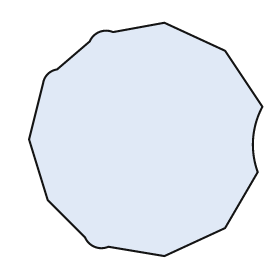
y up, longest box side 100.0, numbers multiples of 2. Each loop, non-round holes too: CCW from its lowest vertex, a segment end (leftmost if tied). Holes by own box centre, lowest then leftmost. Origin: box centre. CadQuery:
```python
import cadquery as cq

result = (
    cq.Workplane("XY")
    .moveTo(8.0, -50.0)
    .lineTo(34.0, -38.0)
    .lineTo(48.0, -14.0)
    .threePointArc((46.0, 0.0), (50.0, 14.0))
    .lineTo(34.0, 38.0)
    .lineTo(8.0, 50.0)
    .lineTo(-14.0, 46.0)
    .threePointArc((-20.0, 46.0), (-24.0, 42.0))
    .lineTo(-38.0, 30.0)
    .threePointArc((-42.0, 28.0), (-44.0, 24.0))
    .lineTo(-50.0, 0.0)
    .lineTo(-42.0, -26.0)
    .lineTo(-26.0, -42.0)
    .threePointArc((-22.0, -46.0), (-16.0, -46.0))
    .close()
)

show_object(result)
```